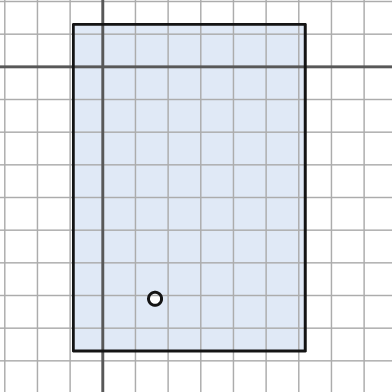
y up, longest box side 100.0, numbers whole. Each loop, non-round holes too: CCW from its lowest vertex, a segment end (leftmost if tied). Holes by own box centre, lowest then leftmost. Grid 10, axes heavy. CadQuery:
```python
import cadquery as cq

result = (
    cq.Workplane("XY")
    .moveTo(-9.0, -87.0)
    .lineTo(62.0, -87.0)
    .lineTo(62.0, 13.0)
    .lineTo(-9.0, 13.0)
    .close()
    .moveTo(16.0, -71.0)
    .circle(2.0)
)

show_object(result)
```